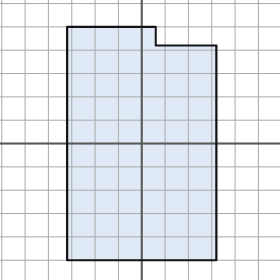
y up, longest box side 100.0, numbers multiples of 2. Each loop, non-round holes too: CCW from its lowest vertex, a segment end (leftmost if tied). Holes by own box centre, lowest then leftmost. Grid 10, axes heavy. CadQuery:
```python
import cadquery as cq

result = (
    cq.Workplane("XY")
    .moveTo(-32.0, -50.0)
    .lineTo(32.0, -50.0)
    .lineTo(32.0, 42.0)
    .lineTo(6.0, 42.0)
    .lineTo(6.0, 50.0)
    .lineTo(-32.0, 50.0)
    .close()
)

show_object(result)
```